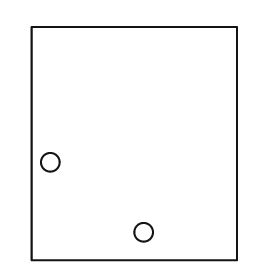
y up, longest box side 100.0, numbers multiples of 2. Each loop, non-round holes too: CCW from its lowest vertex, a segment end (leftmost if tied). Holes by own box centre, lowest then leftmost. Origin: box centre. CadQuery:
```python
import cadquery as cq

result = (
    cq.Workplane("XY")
    .moveTo(-44.0, -50.0)
    .lineTo(44.0, -50.0)
    .lineTo(44.0, 50.0)
    .lineTo(-44.0, 50.0)
    .close()
    .moveTo(4.0, -38.0)
    .circle(4.0)
    .moveTo(-36.0, -8.0)
    .circle(4.0)
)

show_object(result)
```